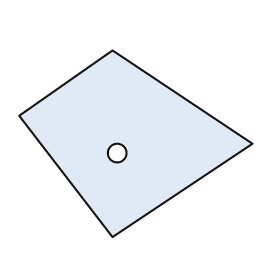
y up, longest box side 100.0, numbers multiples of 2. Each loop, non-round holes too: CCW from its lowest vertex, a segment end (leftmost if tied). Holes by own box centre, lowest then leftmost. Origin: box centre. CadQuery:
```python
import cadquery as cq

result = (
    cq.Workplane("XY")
    .moveTo(-10.0, -40.0)
    .lineTo(50.0, 0.0)
    .lineTo(-10.0, 40.0)
    .lineTo(-50.0, 12.0)
    .close()
    .moveTo(-8.0, -4.0)
    .circle(4.0)
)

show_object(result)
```